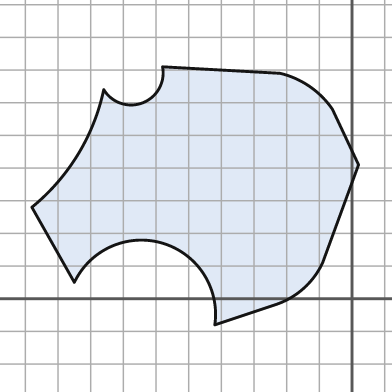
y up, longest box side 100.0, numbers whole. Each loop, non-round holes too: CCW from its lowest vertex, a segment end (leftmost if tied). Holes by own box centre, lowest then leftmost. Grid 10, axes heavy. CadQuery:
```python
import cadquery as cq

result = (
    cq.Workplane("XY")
    .moveTo(-42.0, -8.0)
    .lineTo(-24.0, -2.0)
    .threePointArc((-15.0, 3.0), (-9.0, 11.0))
    .lineTo(2.0, 41.0)
    .lineTo(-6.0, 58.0)
    .threePointArc((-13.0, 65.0), (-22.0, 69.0))
    .lineTo(-58.0, 71.0)
    .threePointArc((-64.0, 60.0), (-76.0, 64.0))
    .threePointArc((-84.0, 44.0), (-98.0, 28.0))
    .lineTo(-85.0, 5.0)
    .threePointArc((-58.0, 17.0), (-42.0, -8.0))
    .close()
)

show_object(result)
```